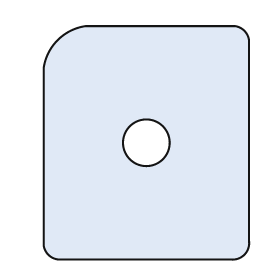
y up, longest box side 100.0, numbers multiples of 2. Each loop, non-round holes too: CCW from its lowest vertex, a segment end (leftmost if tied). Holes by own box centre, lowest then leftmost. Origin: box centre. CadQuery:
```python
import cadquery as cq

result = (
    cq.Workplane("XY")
    .moveTo(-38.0, -50.0)
    .lineTo(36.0, -50.0)
    .threePointArc((42.0, -48.0), (44.0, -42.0))
    .lineTo(44.0, 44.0)
    .threePointArc((42.0, 48.0), (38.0, 50.0))
    .lineTo(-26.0, 50.0)
    .threePointArc((-38.0, 44.0), (-44.0, 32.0))
    .lineTo(-44.0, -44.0)
    .threePointArc((-42.0, -48.0), (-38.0, -50.0))
    .close()
    .moveTo(0.0, 0.0)
    .circle(10.0)
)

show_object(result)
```